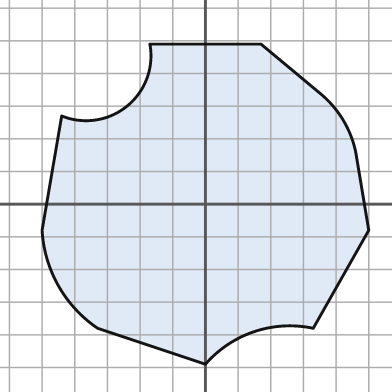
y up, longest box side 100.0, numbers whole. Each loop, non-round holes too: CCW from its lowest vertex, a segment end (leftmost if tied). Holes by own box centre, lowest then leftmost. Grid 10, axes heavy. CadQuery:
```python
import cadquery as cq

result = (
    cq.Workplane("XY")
    .moveTo(0.0, -49.0)
    .threePointArc((15.0, -39.0), (33.0, -38.0))
    .lineTo(50.0, -8.0)
    .lineTo(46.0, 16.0)
    .threePointArc((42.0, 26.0), (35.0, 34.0))
    .lineTo(17.0, 49.0)
    .lineTo(-17.0, 49.0)
    .threePointArc((-24.0, 30.0), (-44.0, 27.0))
    .lineTo(-50.0, -8.0)
    .threePointArc((-45.0, -25.0), (-33.0, -38.0))
    .close()
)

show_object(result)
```